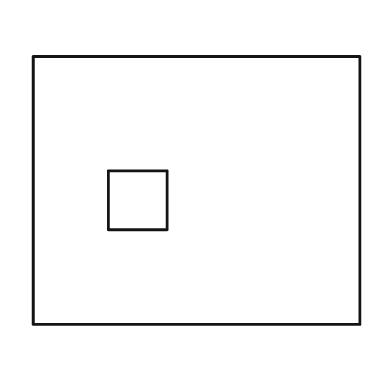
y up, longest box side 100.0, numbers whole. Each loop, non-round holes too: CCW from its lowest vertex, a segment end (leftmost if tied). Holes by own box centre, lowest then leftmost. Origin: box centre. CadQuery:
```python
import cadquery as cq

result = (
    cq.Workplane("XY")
    .moveTo(-50.0, -41.0)
    .lineTo(50.0, -41.0)
    .lineTo(50.0, 41.0)
    .lineTo(-50.0, 41.0)
    .close()
    .moveTo(-27.0, -12.0)
    .lineTo(-9.0, -12.0)
    .lineTo(-9.0, 6.0)
    .lineTo(-27.0, 6.0)
    .close()
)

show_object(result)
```